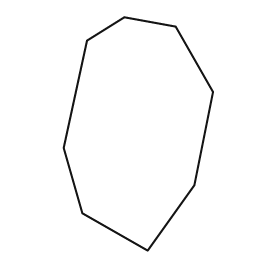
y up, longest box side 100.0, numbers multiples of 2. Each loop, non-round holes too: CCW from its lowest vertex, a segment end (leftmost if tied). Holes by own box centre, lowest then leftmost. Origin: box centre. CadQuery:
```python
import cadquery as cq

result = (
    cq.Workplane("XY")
    .moveTo(4.0, -50.0)
    .lineTo(24.0, -22.0)
    .lineTo(32.0, 18.0)
    .lineTo(16.0, 46.0)
    .lineTo(-6.0, 50.0)
    .lineTo(-22.0, 40.0)
    .lineTo(-32.0, -6.0)
    .lineTo(-24.0, -34.0)
    .close()
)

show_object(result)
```